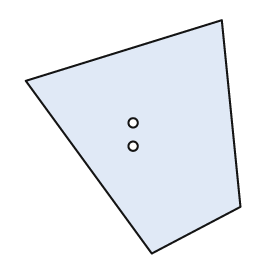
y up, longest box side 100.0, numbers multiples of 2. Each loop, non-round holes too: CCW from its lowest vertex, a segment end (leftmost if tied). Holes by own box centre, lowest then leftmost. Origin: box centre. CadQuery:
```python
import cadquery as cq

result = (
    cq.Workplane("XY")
    .moveTo(8.0, -50.0)
    .lineTo(46.0, -30.0)
    .lineTo(38.0, 50.0)
    .lineTo(-46.0, 24.0)
    .close()
    .moveTo(0.0, -4.0)
    .circle(2.0)
    .moveTo(0.0, 6.0)
    .circle(2.0)
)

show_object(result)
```